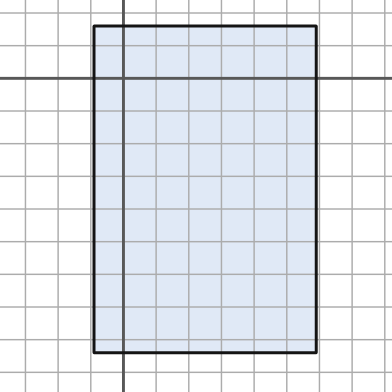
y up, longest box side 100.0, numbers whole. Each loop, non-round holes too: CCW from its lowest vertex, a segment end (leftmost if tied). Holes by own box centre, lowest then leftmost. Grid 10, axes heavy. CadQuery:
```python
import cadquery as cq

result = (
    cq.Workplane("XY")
    .moveTo(-9.0, -84.0)
    .lineTo(59.0, -84.0)
    .lineTo(59.0, 16.0)
    .lineTo(-9.0, 16.0)
    .close()
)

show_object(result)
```